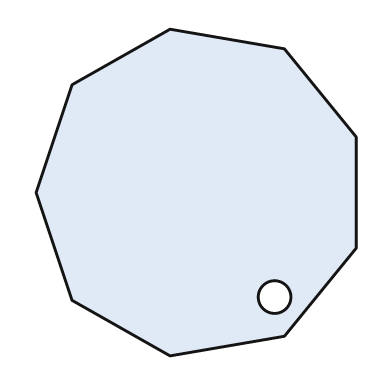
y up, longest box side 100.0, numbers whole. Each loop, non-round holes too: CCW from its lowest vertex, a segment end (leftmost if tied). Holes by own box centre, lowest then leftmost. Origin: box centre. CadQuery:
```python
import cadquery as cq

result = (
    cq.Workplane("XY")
    .moveTo(-8.0, -50.0)
    .lineTo(27.0, -44.0)
    .lineTo(49.0, -17.0)
    .lineTo(49.0, 17.0)
    .lineTo(27.0, 44.0)
    .lineTo(-8.0, 50.0)
    .lineTo(-38.0, 33.0)
    .lineTo(-49.0, 0.0)
    .lineTo(-38.0, -33.0)
    .close()
    .moveTo(24.0, -32.0)
    .circle(5.0)
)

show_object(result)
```